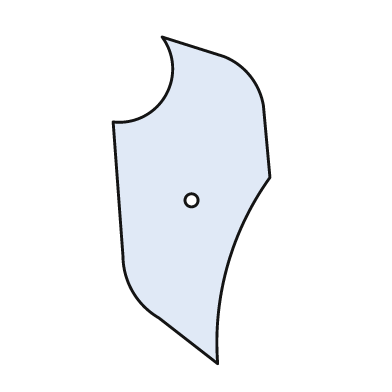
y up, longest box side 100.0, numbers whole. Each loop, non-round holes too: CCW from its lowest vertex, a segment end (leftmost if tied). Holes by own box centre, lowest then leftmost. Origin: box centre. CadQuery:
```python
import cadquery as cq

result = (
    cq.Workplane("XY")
    .moveTo(8.0, -50.0)
    .threePointArc((11.0, -20.0), (24.0, 7.0))
    .lineTo(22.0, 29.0)
    .threePointArc((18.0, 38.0), (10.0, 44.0))
    .lineTo(-9.0, 50.0)
    .threePointArc((-8.0, 32.0), (-24.0, 24.0))
    .lineTo(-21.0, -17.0)
    .threePointArc((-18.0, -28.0), (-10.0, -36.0))
    .close()
    .moveTo(0.0, 0.0)
    .circle(2.0)
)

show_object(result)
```